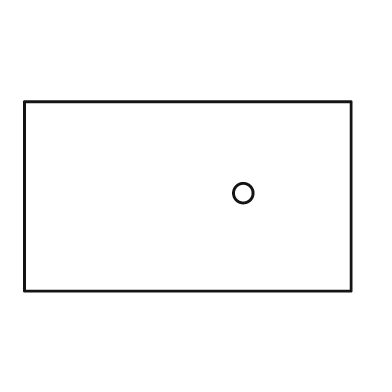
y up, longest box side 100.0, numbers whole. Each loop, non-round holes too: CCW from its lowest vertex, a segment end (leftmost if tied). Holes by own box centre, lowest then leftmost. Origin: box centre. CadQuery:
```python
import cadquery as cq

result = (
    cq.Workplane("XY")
    .moveTo(-50.0, -29.0)
    .lineTo(50.0, -29.0)
    .lineTo(50.0, 29.0)
    .lineTo(-50.0, 29.0)
    .close()
    .moveTo(17.0, 1.0)
    .circle(3.0)
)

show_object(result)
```